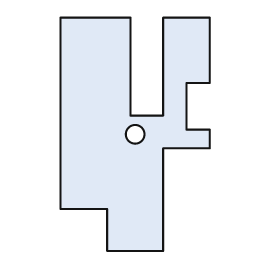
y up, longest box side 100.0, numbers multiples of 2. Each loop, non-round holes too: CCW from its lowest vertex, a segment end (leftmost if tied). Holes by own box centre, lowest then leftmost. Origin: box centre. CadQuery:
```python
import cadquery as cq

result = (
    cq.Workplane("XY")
    .moveTo(-12.0, -50.0)
    .lineTo(12.0, -50.0)
    .lineTo(12.0, -6.0)
    .lineTo(32.0, -6.0)
    .lineTo(32.0, 2.0)
    .lineTo(22.0, 2.0)
    .lineTo(22.0, 22.0)
    .lineTo(32.0, 22.0)
    .lineTo(32.0, 50.0)
    .lineTo(12.0, 50.0)
    .lineTo(12.0, 8.0)
    .lineTo(-2.0, 8.0)
    .lineTo(-2.0, 50.0)
    .lineTo(-32.0, 50.0)
    .lineTo(-32.0, -32.0)
    .lineTo(-12.0, -32.0)
    .close()
    .moveTo(0.0, 0.0)
    .circle(4.0)
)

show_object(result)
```